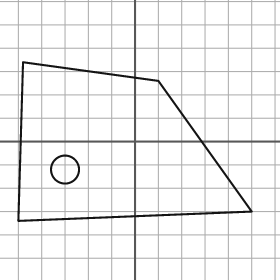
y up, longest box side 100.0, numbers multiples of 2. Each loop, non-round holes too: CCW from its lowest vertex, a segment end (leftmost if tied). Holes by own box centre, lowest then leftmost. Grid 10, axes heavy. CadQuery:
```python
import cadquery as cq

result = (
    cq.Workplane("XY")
    .moveTo(-50.0, -34.0)
    .lineTo(50.0, -30.0)
    .lineTo(10.0, 26.0)
    .lineTo(-48.0, 34.0)
    .close()
    .moveTo(-30.0, -12.0)
    .circle(6.0)
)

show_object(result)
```